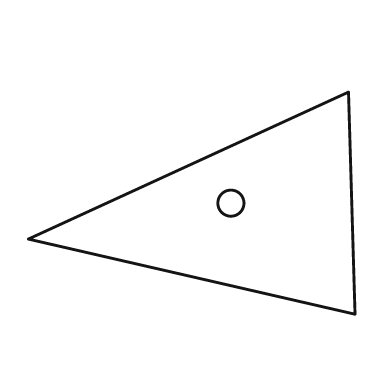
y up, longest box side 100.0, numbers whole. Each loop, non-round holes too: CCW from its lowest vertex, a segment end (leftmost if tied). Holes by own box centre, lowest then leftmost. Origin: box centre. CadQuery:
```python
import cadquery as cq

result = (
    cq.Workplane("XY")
    .moveTo(50.0, -34.0)
    .lineTo(48.0, 34.0)
    .lineTo(-50.0, -11.0)
    .close()
    .moveTo(12.0, 0.0)
    .circle(4.0)
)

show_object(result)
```